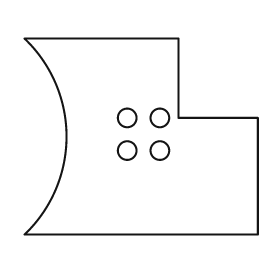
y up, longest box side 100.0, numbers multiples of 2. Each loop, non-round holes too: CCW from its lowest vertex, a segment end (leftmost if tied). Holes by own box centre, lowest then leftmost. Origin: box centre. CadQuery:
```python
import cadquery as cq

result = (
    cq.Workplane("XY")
    .moveTo(-50.0, -42.0)
    .lineTo(50.0, -42.0)
    .lineTo(50.0, 8.0)
    .lineTo(16.0, 8.0)
    .lineTo(16.0, 42.0)
    .lineTo(-50.0, 42.0)
    .threePointArc((-32.0, 0.0), (-50.0, -42.0))
    .close()
    .moveTo(-6.0, -6.0)
    .circle(4.0)
    .moveTo(8.0, -6.0)
    .circle(4.0)
    .moveTo(-6.0, 8.0)
    .circle(4.0)
    .moveTo(8.0, 8.0)
    .circle(4.0)
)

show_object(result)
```